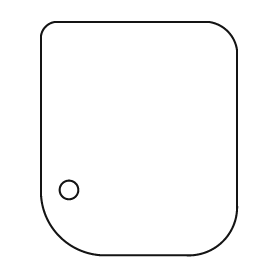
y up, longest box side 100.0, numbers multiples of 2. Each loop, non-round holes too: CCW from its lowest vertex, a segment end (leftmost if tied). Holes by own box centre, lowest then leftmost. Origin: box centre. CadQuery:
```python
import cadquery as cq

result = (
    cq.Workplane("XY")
    .moveTo(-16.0, -50.0)
    .lineTo(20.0, -50.0)
    .threePointArc((36.0, -44.0), (42.0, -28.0))
    .lineTo(42.0, 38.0)
    .threePointArc((38.0, 46.0), (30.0, 50.0))
    .lineTo(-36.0, 50.0)
    .threePointArc((-40.0, 48.0), (-42.0, 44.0))
    .lineTo(-42.0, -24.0)
    .threePointArc((-34.0, -42.0), (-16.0, -50.0))
    .close()
    .moveTo(-30.0, -22.0)
    .circle(4.0)
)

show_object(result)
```